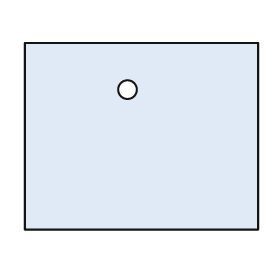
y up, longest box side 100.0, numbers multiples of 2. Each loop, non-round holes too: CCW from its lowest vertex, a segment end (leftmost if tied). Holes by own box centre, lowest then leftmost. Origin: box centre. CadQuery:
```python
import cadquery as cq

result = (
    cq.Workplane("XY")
    .moveTo(-50.0, -40.0)
    .lineTo(50.0, -40.0)
    .lineTo(50.0, 40.0)
    .lineTo(-50.0, 40.0)
    .close()
    .moveTo(-6.0, 20.0)
    .circle(4.0)
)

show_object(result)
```